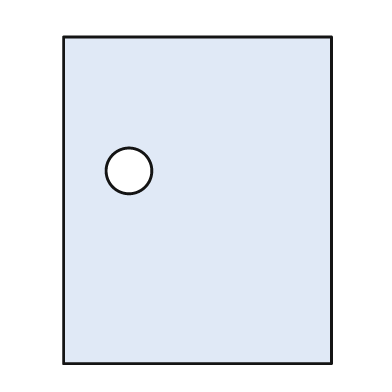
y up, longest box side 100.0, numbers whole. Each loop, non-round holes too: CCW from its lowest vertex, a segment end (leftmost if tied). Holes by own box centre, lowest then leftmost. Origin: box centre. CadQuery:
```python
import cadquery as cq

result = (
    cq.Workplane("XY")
    .moveTo(-41.0, -50.0)
    .lineTo(41.0, -50.0)
    .lineTo(41.0, 50.0)
    .lineTo(-41.0, 50.0)
    .close()
    .moveTo(-21.0, 9.0)
    .circle(7.0)
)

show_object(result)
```